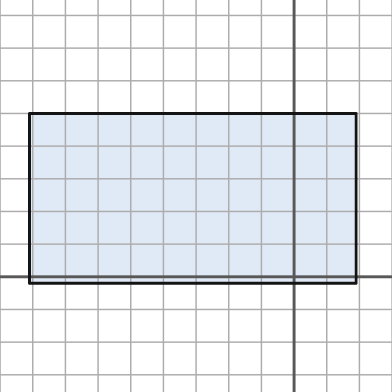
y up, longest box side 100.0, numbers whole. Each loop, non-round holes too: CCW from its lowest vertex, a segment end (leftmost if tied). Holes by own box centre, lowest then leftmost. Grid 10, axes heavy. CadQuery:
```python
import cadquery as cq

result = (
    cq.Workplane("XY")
    .moveTo(-81.0, -2.0)
    .lineTo(19.0, -2.0)
    .lineTo(19.0, 50.0)
    .lineTo(-81.0, 50.0)
    .close()
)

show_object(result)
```